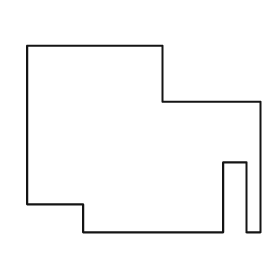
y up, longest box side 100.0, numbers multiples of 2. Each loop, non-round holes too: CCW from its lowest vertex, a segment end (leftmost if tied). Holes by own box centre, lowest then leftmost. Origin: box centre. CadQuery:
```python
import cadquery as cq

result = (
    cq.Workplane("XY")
    .moveTo(-26.0, -40.0)
    .lineTo(34.0, -40.0)
    .lineTo(34.0, -10.0)
    .lineTo(44.0, -10.0)
    .lineTo(44.0, -40.0)
    .lineTo(50.0, -40.0)
    .lineTo(50.0, 16.0)
    .lineTo(8.0, 16.0)
    .lineTo(8.0, 40.0)
    .lineTo(-50.0, 40.0)
    .lineTo(-50.0, -28.0)
    .lineTo(-26.0, -28.0)
    .close()
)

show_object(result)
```